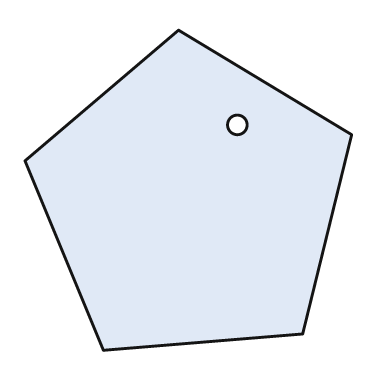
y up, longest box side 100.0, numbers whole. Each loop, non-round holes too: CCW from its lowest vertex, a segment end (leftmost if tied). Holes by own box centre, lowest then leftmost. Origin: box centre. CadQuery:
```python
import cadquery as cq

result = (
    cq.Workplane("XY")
    .moveTo(-26.0, -49.0)
    .lineTo(35.0, -44.0)
    .lineTo(50.0, 17.0)
    .lineTo(-3.0, 49.0)
    .lineTo(-50.0, 9.0)
    .close()
    .moveTo(15.0, 20.0)
    .circle(3.0)
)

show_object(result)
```